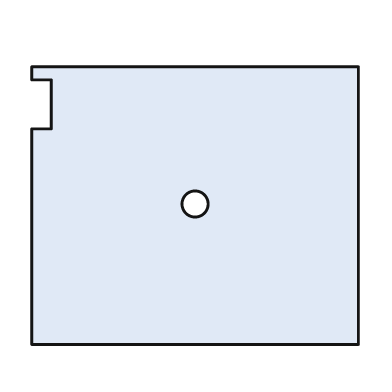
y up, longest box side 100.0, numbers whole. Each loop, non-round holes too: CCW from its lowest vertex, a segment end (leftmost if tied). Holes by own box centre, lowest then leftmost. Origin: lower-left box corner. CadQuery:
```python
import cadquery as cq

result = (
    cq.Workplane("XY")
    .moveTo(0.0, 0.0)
    .lineTo(100.0, 0.0)
    .lineTo(100.0, 85.0)
    .lineTo(0.0, 85.0)
    .lineTo(0.0, 81.0)
    .lineTo(6.0, 81.0)
    .lineTo(6.0, 66.0)
    .lineTo(0.0, 66.0)
    .close()
    .moveTo(50.0, 43.0)
    .circle(4.0)
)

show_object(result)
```